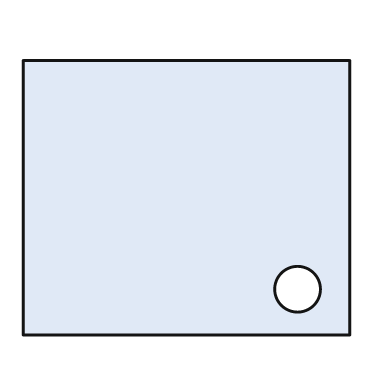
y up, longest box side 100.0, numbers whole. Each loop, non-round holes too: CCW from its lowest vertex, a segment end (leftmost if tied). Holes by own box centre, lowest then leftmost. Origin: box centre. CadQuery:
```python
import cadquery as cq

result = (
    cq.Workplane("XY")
    .moveTo(-50.0, -42.0)
    .lineTo(50.0, -42.0)
    .lineTo(50.0, 42.0)
    .lineTo(-50.0, 42.0)
    .close()
    .moveTo(34.0, -28.0)
    .circle(7.0)
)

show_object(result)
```